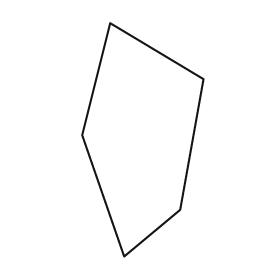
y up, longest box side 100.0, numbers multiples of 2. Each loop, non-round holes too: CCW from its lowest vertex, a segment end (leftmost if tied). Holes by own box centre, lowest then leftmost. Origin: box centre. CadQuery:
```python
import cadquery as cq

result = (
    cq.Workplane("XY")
    .moveTo(-8.0, -50.0)
    .lineTo(16.0, -30.0)
    .lineTo(26.0, 26.0)
    .lineTo(-14.0, 50.0)
    .lineTo(-26.0, 2.0)
    .close()
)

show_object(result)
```